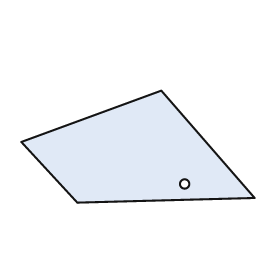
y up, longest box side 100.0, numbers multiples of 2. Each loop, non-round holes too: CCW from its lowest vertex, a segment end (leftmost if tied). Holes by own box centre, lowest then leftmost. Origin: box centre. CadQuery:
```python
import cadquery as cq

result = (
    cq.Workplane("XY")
    .moveTo(-26.0, -24.0)
    .lineTo(50.0, -22.0)
    .lineTo(10.0, 24.0)
    .lineTo(-50.0, 2.0)
    .close()
    .moveTo(20.0, -16.0)
    .circle(2.0)
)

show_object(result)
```